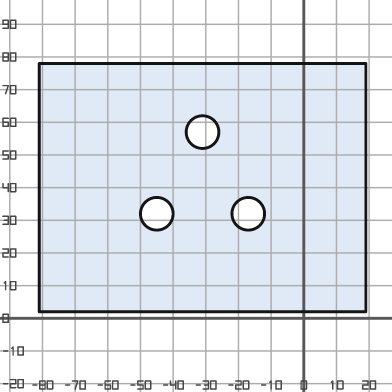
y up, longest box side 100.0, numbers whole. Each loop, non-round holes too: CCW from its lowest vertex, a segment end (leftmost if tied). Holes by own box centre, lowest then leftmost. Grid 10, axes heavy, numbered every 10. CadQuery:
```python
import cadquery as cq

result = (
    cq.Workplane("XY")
    .moveTo(-81.0, 2.0)
    .lineTo(19.0, 2.0)
    .lineTo(19.0, 78.0)
    .lineTo(-81.0, 78.0)
    .close()
    .moveTo(-45.0, 32.0)
    .circle(5.0)
    .moveTo(-17.0, 32.0)
    .circle(5.0)
    .moveTo(-31.0, 57.0)
    .circle(5.0)
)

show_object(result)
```